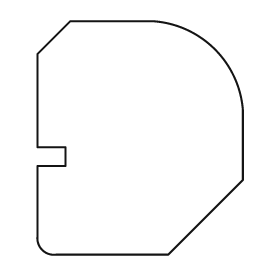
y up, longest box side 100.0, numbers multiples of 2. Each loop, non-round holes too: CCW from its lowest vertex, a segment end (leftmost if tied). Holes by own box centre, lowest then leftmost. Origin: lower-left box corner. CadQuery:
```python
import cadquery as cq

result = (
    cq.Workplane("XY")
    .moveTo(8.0, 0.0)
    .lineTo(56.0, 0.0)
    .lineTo(88.0, 32.0)
    .lineTo(88.0, 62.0)
    .threePointArc((76.0, 88.0), (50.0, 100.0))
    .lineTo(14.0, 100.0)
    .lineTo(0.0, 86.0)
    .lineTo(0.0, 46.0)
    .lineTo(12.0, 46.0)
    .lineTo(12.0, 38.0)
    .lineTo(0.0, 38.0)
    .lineTo(0.0, 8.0)
    .threePointArc((2.0, 2.0), (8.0, 0.0))
    .close()
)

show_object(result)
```